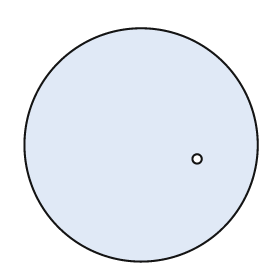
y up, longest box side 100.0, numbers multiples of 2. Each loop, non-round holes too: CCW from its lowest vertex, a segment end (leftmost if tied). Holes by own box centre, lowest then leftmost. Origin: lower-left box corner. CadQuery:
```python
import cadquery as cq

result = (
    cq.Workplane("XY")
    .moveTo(50.0, 50.0)
    .circle(50.0)
    .moveTo(74.0, 44.0)
    .circle(2.0)
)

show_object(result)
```